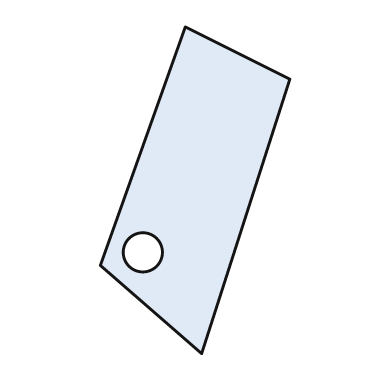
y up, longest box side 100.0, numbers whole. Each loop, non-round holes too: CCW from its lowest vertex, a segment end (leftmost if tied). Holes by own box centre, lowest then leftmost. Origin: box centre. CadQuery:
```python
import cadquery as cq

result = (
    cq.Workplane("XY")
    .moveTo(2.0, -50.0)
    .lineTo(29.0, 34.0)
    .lineTo(-3.0, 50.0)
    .lineTo(-29.0, -23.0)
    .close()
    .moveTo(-16.0, -19.0)
    .circle(6.0)
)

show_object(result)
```